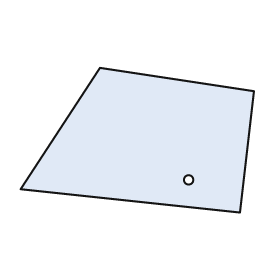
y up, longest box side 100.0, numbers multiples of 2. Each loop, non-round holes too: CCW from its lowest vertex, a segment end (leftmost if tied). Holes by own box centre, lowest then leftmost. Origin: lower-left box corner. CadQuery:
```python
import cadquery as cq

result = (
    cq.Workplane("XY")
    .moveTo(94.0, 0.0)
    .lineTo(100.0, 52.0)
    .lineTo(34.0, 62.0)
    .lineTo(0.0, 10.0)
    .close()
    .moveTo(72.0, 14.0)
    .circle(2.0)
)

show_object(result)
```